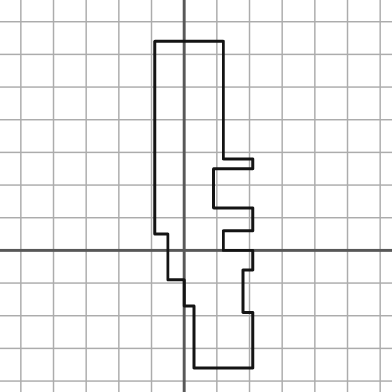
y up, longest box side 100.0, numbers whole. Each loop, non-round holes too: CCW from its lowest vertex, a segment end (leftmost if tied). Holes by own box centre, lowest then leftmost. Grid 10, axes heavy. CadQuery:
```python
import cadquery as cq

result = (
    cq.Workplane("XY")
    .moveTo(3.0, -36.0)
    .lineTo(21.0, -36.0)
    .lineTo(21.0, -19.0)
    .lineTo(18.0, -19.0)
    .lineTo(18.0, -6.0)
    .lineTo(21.0, -6.0)
    .lineTo(21.0, 0.0)
    .lineTo(12.0, 0.0)
    .lineTo(12.0, 6.0)
    .lineTo(21.0, 6.0)
    .lineTo(21.0, 13.0)
    .lineTo(9.0, 13.0)
    .lineTo(9.0, 25.0)
    .lineTo(21.0, 25.0)
    .lineTo(21.0, 28.0)
    .lineTo(12.0, 28.0)
    .lineTo(12.0, 64.0)
    .lineTo(-9.0, 64.0)
    .lineTo(-9.0, 5.0)
    .lineTo(-5.0, 5.0)
    .lineTo(-5.0, -9.0)
    .lineTo(0.0, -9.0)
    .lineTo(0.0, -17.0)
    .lineTo(3.0, -17.0)
    .close()
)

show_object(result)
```